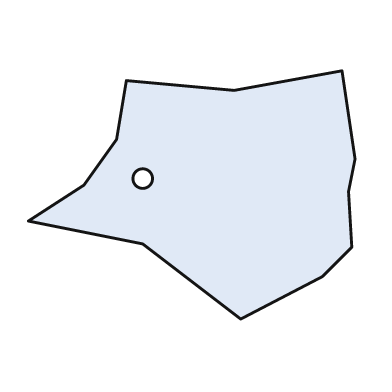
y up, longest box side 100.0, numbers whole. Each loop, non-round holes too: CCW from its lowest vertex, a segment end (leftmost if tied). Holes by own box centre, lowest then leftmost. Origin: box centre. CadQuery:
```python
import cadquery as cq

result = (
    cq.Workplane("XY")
    .moveTo(15.0, -38.0)
    .lineTo(40.0, -25.0)
    .lineTo(49.0, -16.0)
    .lineTo(48.0, 1.0)
    .lineTo(50.0, 11.0)
    .lineTo(46.0, 38.0)
    .lineTo(13.0, 32.0)
    .lineTo(-20.0, 35.0)
    .lineTo(-23.0, 17.0)
    .lineTo(-33.0, 3.0)
    .lineTo(-50.0, -8.0)
    .lineTo(-15.0, -15.0)
    .close()
    .moveTo(-15.0, 5.0)
    .circle(3.0)
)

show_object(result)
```